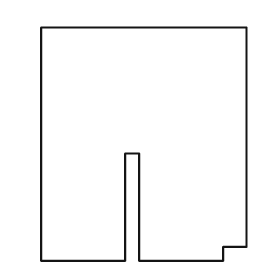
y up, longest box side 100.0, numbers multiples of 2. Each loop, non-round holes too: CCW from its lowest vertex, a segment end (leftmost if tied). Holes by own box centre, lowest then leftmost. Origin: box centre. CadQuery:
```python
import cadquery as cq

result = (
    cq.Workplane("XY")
    .moveTo(-44.0, -50.0)
    .lineTo(-8.0, -50.0)
    .lineTo(-8.0, -4.0)
    .lineTo(-2.0, -4.0)
    .lineTo(-2.0, -50.0)
    .lineTo(34.0, -50.0)
    .lineTo(34.0, -44.0)
    .lineTo(44.0, -44.0)
    .lineTo(44.0, 50.0)
    .lineTo(-44.0, 50.0)
    .close()
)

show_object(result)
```